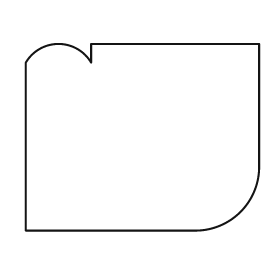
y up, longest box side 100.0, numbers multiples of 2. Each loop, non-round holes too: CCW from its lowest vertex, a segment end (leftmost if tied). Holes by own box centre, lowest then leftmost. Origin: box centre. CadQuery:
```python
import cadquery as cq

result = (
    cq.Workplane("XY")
    .moveTo(-50.0, -40.0)
    .lineTo(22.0, -40.0)
    .threePointArc((42.0, -32.0), (50.0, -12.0))
    .lineTo(50.0, 40.0)
    .lineTo(-22.0, 40.0)
    .lineTo(-22.0, 32.0)
    .threePointArc((-36.0, 40.0), (-50.0, 32.0))
    .close()
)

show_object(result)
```